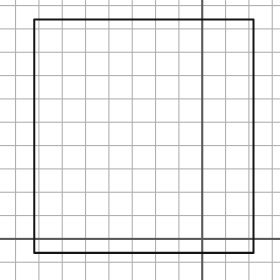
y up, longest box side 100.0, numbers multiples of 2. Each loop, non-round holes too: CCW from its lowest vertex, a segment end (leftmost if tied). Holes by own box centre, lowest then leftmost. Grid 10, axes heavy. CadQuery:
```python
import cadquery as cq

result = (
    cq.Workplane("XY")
    .moveTo(-72.0, -6.0)
    .lineTo(22.0, -6.0)
    .lineTo(22.0, 94.0)
    .lineTo(-72.0, 94.0)
    .close()
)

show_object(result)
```